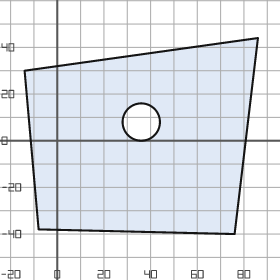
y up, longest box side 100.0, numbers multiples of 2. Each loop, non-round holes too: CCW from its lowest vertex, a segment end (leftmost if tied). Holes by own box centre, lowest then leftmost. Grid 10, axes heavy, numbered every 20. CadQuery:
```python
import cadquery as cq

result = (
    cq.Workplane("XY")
    .moveTo(76.0, -40.0)
    .lineTo(86.0, 44.0)
    .lineTo(-14.0, 30.0)
    .lineTo(-8.0, -38.0)
    .close()
    .moveTo(36.0, 8.0)
    .circle(8.0)
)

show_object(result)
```